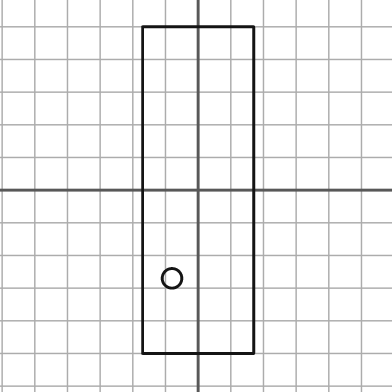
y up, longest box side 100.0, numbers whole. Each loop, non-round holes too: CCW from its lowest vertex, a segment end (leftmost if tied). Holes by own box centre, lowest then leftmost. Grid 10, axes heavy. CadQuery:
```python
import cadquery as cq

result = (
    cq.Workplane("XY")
    .moveTo(-17.0, -50.0)
    .lineTo(17.0, -50.0)
    .lineTo(17.0, 50.0)
    .lineTo(-17.0, 50.0)
    .close()
    .moveTo(-8.0, -27.0)
    .circle(3.0)
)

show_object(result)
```